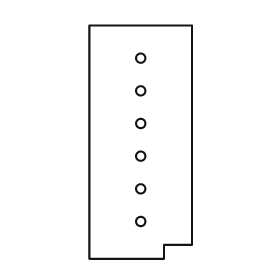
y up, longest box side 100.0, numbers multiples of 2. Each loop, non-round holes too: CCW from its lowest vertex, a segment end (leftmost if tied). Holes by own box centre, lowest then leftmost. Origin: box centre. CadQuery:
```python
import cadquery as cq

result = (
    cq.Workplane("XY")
    .moveTo(-22.0, -50.0)
    .lineTo(10.0, -50.0)
    .lineTo(10.0, -44.0)
    .lineTo(22.0, -44.0)
    .lineTo(22.0, 50.0)
    .lineTo(-22.0, 50.0)
    .close()
    .moveTo(0.0, -34.0)
    .circle(2.0)
    .moveTo(0.0, -20.0)
    .circle(2.0)
    .moveTo(0.0, -6.0)
    .circle(2.0)
    .moveTo(0.0, 8.0)
    .circle(2.0)
    .moveTo(0.0, 22.0)
    .circle(2.0)
    .moveTo(0.0, 36.0)
    .circle(2.0)
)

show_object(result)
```